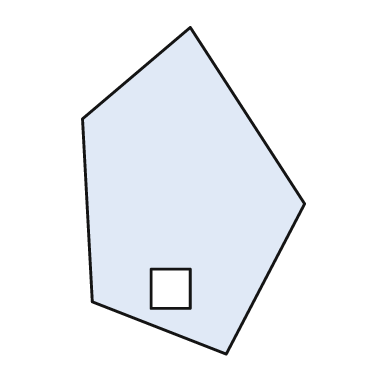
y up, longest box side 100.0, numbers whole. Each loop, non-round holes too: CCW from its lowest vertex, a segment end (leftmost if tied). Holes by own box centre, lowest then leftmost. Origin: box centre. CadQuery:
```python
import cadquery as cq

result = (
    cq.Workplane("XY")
    .moveTo(10.0, -50.0)
    .lineTo(34.0, -4.0)
    .lineTo(-1.0, 50.0)
    .lineTo(-34.0, 22.0)
    .lineTo(-31.0, -34.0)
    .close()
    .moveTo(-13.0, -36.0)
    .lineTo(-1.0, -36.0)
    .lineTo(-1.0, -24.0)
    .lineTo(-13.0, -24.0)
    .close()
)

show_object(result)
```